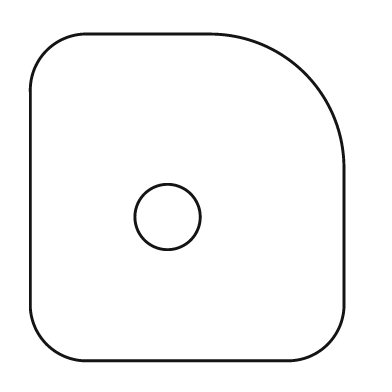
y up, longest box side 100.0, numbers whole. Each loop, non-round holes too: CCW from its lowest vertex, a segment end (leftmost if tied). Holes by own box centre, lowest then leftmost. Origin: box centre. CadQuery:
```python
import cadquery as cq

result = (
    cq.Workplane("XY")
    .moveTo(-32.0, -50.0)
    .lineTo(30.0, -50.0)
    .threePointArc((43.0, -45.0), (48.0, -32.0))
    .lineTo(48.0, 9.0)
    .threePointArc((36.0, 38.0), (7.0, 50.0))
    .lineTo(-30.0, 50.0)
    .threePointArc((-43.0, 45.0), (-48.0, 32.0))
    .lineTo(-48.0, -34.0)
    .threePointArc((-43.0, -45.0), (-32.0, -50.0))
    .close()
    .moveTo(-6.0, -6.0)
    .circle(10.0)
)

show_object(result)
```